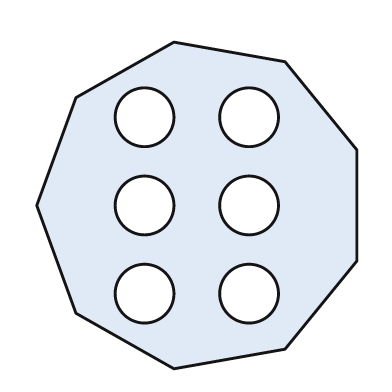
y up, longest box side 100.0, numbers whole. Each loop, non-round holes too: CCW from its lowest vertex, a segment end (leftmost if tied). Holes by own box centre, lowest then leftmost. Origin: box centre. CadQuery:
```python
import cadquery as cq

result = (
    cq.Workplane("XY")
    .moveTo(-7.0, -50.0)
    .lineTo(27.0, -44.0)
    .lineTo(49.0, -17.0)
    .lineTo(49.0, 17.0)
    .lineTo(27.0, 44.0)
    .lineTo(-7.0, 50.0)
    .lineTo(-37.0, 33.0)
    .lineTo(-49.0, 0.0)
    .lineTo(-37.0, -33.0)
    .close()
    .moveTo(-16.0, -27.0)
    .circle(9.0)
    .moveTo(16.0, -27.0)
    .circle(9.0)
    .moveTo(-16.0, 0.0)
    .circle(9.0)
    .moveTo(16.0, 0.0)
    .circle(9.0)
    .moveTo(-16.0, 27.0)
    .circle(9.0)
    .moveTo(16.0, 27.0)
    .circle(9.0)
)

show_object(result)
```